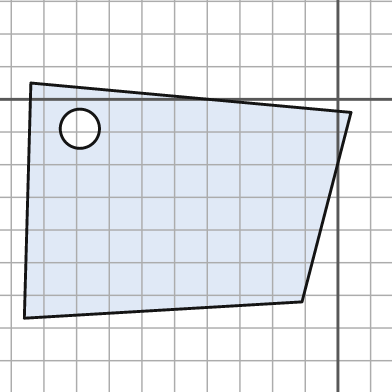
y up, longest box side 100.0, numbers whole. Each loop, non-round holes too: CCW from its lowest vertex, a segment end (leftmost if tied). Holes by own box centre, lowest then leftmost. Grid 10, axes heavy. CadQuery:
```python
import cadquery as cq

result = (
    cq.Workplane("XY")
    .moveTo(-96.0, -67.0)
    .lineTo(-11.0, -62.0)
    .lineTo(4.0, -4.0)
    .lineTo(-94.0, 5.0)
    .close()
    .moveTo(-79.0, -9.0)
    .circle(6.0)
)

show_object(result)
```